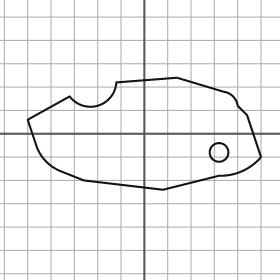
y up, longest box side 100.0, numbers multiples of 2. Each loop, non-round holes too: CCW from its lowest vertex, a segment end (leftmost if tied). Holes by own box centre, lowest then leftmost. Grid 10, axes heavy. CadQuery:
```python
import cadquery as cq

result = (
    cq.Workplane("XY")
    .moveTo(8.0, -24.0)
    .lineTo(32.0, -18.0)
    .threePointArc((42.0, -16.0), (50.0, -10.0))
    .lineTo(44.0, 8.0)
    .lineTo(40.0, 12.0)
    .threePointArc((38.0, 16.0), (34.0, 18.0))
    .lineTo(14.0, 24.0)
    .lineTo(-12.0, 22.0)
    .threePointArc((-20.0, 12.0), (-32.0, 16.0))
    .lineTo(-50.0, 6.0)
    .lineTo(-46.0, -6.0)
    .threePointArc((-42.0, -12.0), (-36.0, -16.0))
    .lineTo(-26.0, -20.0)
    .close()
    .moveTo(32.0, -8.0)
    .circle(4.0)
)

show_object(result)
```